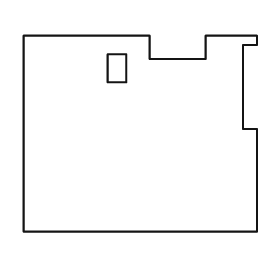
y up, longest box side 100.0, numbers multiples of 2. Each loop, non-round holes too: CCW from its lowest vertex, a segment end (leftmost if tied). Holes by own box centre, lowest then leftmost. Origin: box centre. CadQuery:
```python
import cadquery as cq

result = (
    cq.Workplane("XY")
    .moveTo(-50.0, -42.0)
    .lineTo(50.0, -42.0)
    .lineTo(50.0, 2.0)
    .lineTo(44.0, 2.0)
    .lineTo(44.0, 38.0)
    .lineTo(50.0, 38.0)
    .lineTo(50.0, 42.0)
    .lineTo(28.0, 42.0)
    .lineTo(28.0, 32.0)
    .lineTo(4.0, 32.0)
    .lineTo(4.0, 42.0)
    .lineTo(-50.0, 42.0)
    .close()
    .moveTo(-14.0, 22.0)
    .lineTo(-6.0, 22.0)
    .lineTo(-6.0, 34.0)
    .lineTo(-14.0, 34.0)
    .close()
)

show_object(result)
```